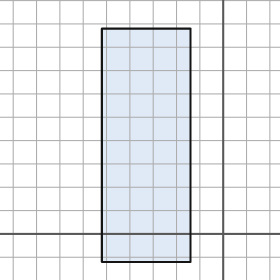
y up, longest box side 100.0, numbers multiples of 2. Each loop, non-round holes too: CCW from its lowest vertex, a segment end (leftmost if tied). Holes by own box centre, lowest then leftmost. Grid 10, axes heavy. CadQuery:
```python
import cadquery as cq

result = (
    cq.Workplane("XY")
    .moveTo(-52.0, -12.0)
    .lineTo(-14.0, -12.0)
    .lineTo(-14.0, 88.0)
    .lineTo(-52.0, 88.0)
    .close()
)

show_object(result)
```